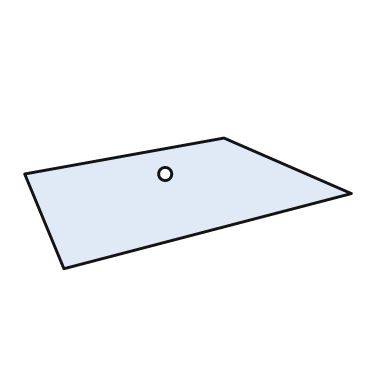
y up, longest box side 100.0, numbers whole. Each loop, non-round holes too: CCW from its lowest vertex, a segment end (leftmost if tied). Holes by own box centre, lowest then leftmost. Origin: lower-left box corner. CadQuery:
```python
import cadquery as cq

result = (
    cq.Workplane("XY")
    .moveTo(12.0, 0.0)
    .lineTo(100.0, 23.0)
    .lineTo(61.0, 40.0)
    .lineTo(0.0, 29.0)
    .close()
    .moveTo(43.0, 29.0)
    .circle(2.0)
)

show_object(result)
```